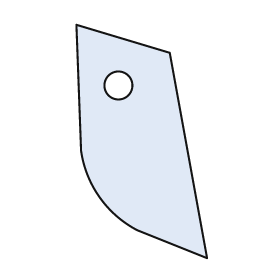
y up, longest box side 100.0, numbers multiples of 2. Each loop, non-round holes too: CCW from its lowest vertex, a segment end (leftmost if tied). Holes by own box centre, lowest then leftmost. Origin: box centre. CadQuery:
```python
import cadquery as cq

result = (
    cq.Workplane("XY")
    .moveTo(28.0, -50.0)
    .lineTo(12.0, 38.0)
    .lineTo(-28.0, 50.0)
    .lineTo(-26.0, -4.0)
    .threePointArc((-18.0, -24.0), (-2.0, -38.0))
    .close()
    .moveTo(-10.0, 24.0)
    .circle(6.0)
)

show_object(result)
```